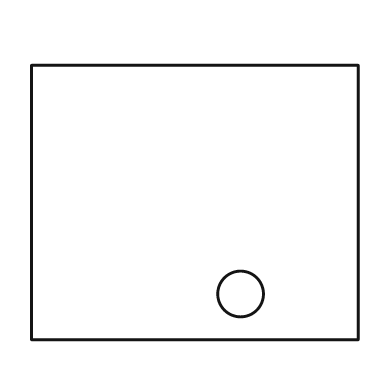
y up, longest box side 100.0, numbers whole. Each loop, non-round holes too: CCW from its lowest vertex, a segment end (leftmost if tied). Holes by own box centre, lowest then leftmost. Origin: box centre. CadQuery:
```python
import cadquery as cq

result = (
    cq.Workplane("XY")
    .moveTo(-50.0, -42.0)
    .lineTo(50.0, -42.0)
    .lineTo(50.0, 42.0)
    .lineTo(-50.0, 42.0)
    .close()
    .moveTo(14.0, -28.0)
    .circle(7.0)
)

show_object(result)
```